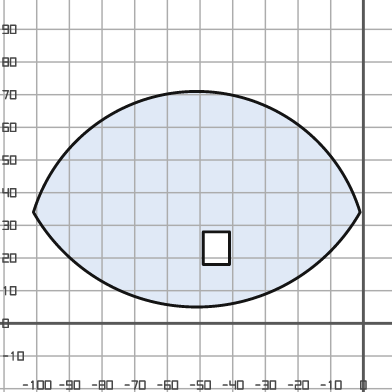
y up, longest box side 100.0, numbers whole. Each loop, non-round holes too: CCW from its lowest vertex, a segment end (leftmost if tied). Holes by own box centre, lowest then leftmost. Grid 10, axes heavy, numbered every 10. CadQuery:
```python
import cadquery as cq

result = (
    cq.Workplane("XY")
    .moveTo(-101.0, 34.0)
    .threePointArc((-51.0, 5.0), (-1.0, 34.0))
    .threePointArc((-51.0, 71.0), (-101.0, 34.0))
    .close()
    .moveTo(-49.0, 18.0)
    .lineTo(-41.0, 18.0)
    .lineTo(-41.0, 28.0)
    .lineTo(-49.0, 28.0)
    .close()
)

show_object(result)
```